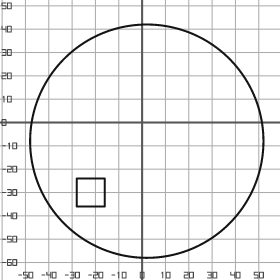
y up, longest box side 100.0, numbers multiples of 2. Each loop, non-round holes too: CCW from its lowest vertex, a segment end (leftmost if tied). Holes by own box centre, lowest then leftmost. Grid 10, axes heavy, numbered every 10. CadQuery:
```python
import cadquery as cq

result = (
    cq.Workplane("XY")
    .moveTo(2.0, -8.0)
    .circle(50.0)
    .moveTo(-28.0, -36.0)
    .lineTo(-16.0, -36.0)
    .lineTo(-16.0, -24.0)
    .lineTo(-28.0, -24.0)
    .close()
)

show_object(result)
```